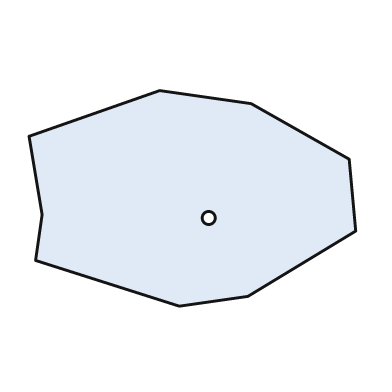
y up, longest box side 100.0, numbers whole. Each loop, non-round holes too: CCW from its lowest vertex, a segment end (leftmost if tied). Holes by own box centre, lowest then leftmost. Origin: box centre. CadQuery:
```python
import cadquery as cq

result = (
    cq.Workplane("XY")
    .moveTo(-4.0, -33.0)
    .lineTo(17.0, -30.0)
    .lineTo(50.0, -10.0)
    .lineTo(48.0, 12.0)
    .lineTo(18.0, 29.0)
    .lineTo(-10.0, 33.0)
    .lineTo(-50.0, 19.0)
    .lineTo(-46.0, -5.0)
    .lineTo(-48.0, -19.0)
    .close()
    .moveTo(5.0, -6.0)
    .circle(2.0)
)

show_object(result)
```